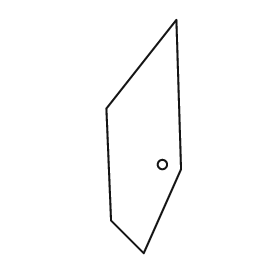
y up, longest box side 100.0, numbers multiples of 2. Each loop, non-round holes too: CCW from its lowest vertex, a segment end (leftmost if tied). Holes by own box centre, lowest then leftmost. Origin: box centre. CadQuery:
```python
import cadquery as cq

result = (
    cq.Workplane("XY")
    .moveTo(0.0, -50.0)
    .lineTo(16.0, -14.0)
    .lineTo(14.0, 50.0)
    .lineTo(-16.0, 12.0)
    .lineTo(-14.0, -36.0)
    .close()
    .moveTo(8.0, -12.0)
    .circle(2.0)
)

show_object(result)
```